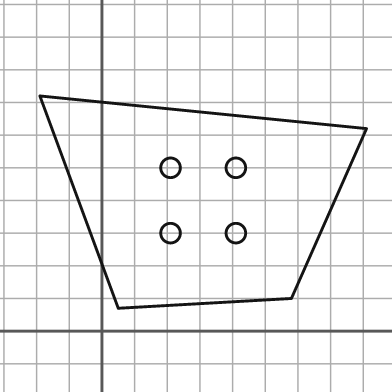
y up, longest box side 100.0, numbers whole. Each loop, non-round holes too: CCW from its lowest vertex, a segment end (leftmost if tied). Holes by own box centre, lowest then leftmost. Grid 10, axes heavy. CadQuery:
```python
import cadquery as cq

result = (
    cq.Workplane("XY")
    .moveTo(5.0, 7.0)
    .lineTo(58.0, 10.0)
    .lineTo(81.0, 62.0)
    .lineTo(-19.0, 72.0)
    .close()
    .moveTo(21.0, 30.0)
    .circle(3.0)
    .moveTo(41.0, 30.0)
    .circle(3.0)
    .moveTo(21.0, 50.0)
    .circle(3.0)
    .moveTo(41.0, 50.0)
    .circle(3.0)
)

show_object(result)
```